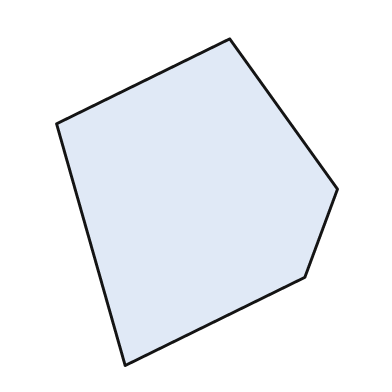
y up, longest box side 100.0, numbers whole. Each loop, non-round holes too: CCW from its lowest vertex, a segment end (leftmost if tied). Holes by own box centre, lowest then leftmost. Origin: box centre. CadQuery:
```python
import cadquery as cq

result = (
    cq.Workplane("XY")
    .moveTo(-22.0, -50.0)
    .lineTo(33.0, -23.0)
    .lineTo(43.0, 4.0)
    .lineTo(10.0, 50.0)
    .lineTo(-43.0, 24.0)
    .close()
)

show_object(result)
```